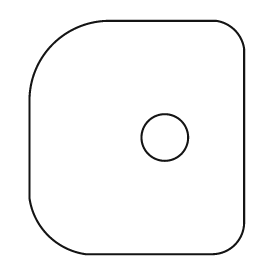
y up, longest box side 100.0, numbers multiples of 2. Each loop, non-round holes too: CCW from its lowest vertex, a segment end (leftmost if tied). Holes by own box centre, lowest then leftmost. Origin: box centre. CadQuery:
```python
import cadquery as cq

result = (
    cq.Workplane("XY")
    .moveTo(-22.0, -50.0)
    .lineTo(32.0, -50.0)
    .threePointArc((42.0, -46.0), (46.0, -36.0))
    .lineTo(46.0, 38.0)
    .threePointArc((42.0, 46.0), (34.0, 50.0))
    .lineTo(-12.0, 50.0)
    .threePointArc((-36.0, 40.0), (-46.0, 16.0))
    .lineTo(-46.0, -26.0)
    .threePointArc((-38.0, -42.0), (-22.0, -50.0))
    .close()
    .moveTo(12.0, 0.0)
    .circle(10.0)
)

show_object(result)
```